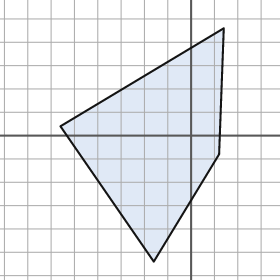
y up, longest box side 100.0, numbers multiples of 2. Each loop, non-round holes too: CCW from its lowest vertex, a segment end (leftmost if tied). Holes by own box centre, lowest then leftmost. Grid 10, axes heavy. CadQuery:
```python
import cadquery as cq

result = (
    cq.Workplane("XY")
    .moveTo(-16.0, -54.0)
    .lineTo(12.0, -8.0)
    .lineTo(14.0, 46.0)
    .lineTo(-56.0, 4.0)
    .close()
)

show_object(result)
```